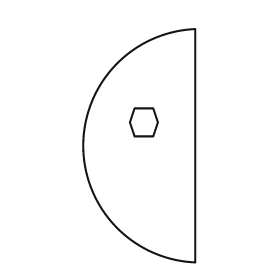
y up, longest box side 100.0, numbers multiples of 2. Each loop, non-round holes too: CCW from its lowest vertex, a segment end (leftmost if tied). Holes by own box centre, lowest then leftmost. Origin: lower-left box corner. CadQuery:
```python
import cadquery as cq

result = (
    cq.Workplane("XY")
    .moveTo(48.0, 0.0)
    .lineTo(48.0, 100.0)
    .threePointArc((0.0, 50.0), (48.0, 0.0))
    .close()
    .moveTo(22.0, 54.0)
    .lineTo(30.0, 54.0)
    .lineTo(32.0, 60.0)
    .lineTo(30.0, 66.0)
    .lineTo(22.0, 66.0)
    .lineTo(20.0, 60.0)
    .close()
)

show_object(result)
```